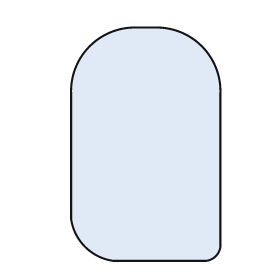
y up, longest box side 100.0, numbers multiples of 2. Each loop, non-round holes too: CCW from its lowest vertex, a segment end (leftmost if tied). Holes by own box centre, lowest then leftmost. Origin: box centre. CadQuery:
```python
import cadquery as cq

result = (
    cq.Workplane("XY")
    .moveTo(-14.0, -50.0)
    .lineTo(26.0, -50.0)
    .threePointArc((30.0, -48.0), (32.0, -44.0))
    .lineTo(32.0, 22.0)
    .threePointArc((24.0, 42.0), (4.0, 50.0))
    .lineTo(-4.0, 50.0)
    .threePointArc((-24.0, 42.0), (-32.0, 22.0))
    .lineTo(-32.0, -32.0)
    .threePointArc((-26.0, -44.0), (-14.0, -50.0))
    .close()
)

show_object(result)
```